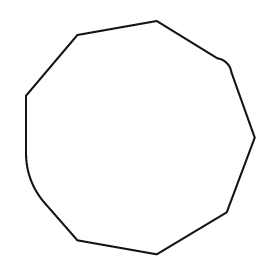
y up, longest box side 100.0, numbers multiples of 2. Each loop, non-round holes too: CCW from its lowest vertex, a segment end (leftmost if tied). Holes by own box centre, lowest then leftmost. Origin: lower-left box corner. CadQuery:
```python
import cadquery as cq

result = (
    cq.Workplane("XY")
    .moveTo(56.0, 0.0)
    .lineTo(86.0, 18.0)
    .lineTo(98.0, 50.0)
    .lineTo(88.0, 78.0)
    .threePointArc((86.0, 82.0), (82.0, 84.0))
    .lineTo(56.0, 100.0)
    .lineTo(22.0, 94.0)
    .lineTo(0.0, 68.0)
    .lineTo(0.0, 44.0)
    .threePointArc((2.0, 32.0), (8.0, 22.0))
    .lineTo(22.0, 6.0)
    .close()
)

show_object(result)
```